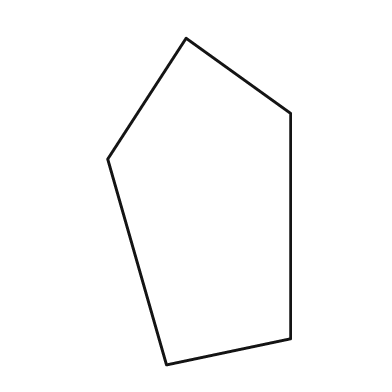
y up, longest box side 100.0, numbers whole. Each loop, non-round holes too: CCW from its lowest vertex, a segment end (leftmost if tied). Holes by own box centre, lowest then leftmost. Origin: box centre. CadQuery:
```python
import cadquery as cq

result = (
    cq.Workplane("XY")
    .moveTo(-10.0, -50.0)
    .lineTo(28.0, -42.0)
    .lineTo(28.0, 27.0)
    .lineTo(-4.0, 50.0)
    .lineTo(-28.0, 13.0)
    .close()
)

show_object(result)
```